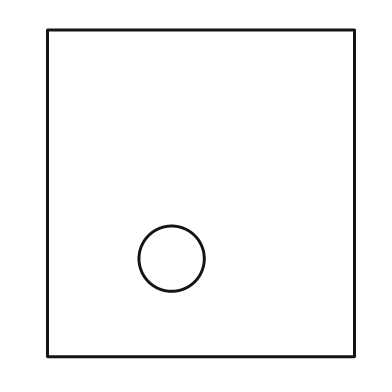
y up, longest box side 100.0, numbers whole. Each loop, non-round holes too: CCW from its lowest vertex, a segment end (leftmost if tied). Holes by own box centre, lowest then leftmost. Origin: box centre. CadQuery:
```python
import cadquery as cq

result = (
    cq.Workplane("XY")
    .moveTo(-47.0, -50.0)
    .lineTo(47.0, -50.0)
    .lineTo(47.0, 50.0)
    .lineTo(-47.0, 50.0)
    .close()
    .moveTo(-9.0, -20.0)
    .circle(10.0)
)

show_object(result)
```